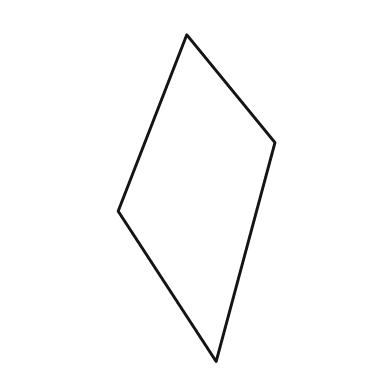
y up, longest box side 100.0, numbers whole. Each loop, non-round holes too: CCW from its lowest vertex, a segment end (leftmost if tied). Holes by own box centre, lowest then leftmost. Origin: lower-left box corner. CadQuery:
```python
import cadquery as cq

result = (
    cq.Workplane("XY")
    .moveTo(30.0, 0.0)
    .lineTo(48.0, 67.0)
    .lineTo(21.0, 100.0)
    .lineTo(0.0, 46.0)
    .close()
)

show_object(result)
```